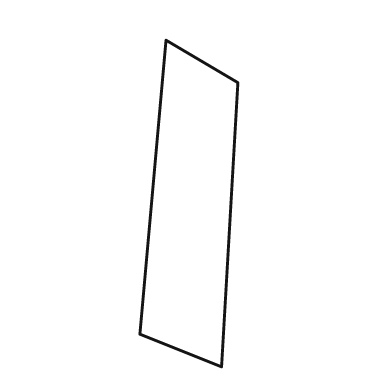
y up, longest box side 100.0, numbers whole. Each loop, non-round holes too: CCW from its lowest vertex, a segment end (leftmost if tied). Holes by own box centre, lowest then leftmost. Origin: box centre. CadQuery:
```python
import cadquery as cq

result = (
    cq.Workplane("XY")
    .moveTo(10.0, -50.0)
    .lineTo(15.0, 37.0)
    .lineTo(-7.0, 50.0)
    .lineTo(-15.0, -40.0)
    .close()
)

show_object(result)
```